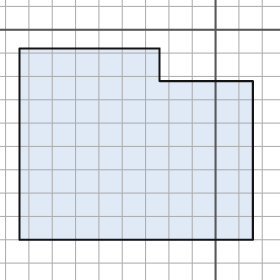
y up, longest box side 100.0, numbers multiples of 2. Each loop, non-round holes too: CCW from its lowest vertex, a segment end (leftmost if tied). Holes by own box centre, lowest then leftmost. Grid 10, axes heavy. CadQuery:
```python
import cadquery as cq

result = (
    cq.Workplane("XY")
    .moveTo(-84.0, -90.0)
    .lineTo(16.0, -90.0)
    .lineTo(16.0, -22.0)
    .lineTo(-24.0, -22.0)
    .lineTo(-24.0, -8.0)
    .lineTo(-84.0, -8.0)
    .close()
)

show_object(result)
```